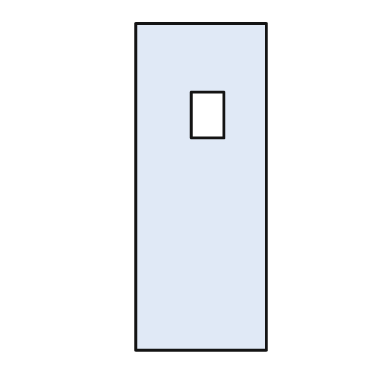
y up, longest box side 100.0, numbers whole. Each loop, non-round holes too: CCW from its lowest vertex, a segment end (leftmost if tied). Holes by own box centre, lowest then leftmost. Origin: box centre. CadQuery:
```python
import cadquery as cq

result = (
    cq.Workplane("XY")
    .moveTo(-20.0, -50.0)
    .lineTo(20.0, -50.0)
    .lineTo(20.0, 50.0)
    .lineTo(-20.0, 50.0)
    .close()
    .moveTo(-3.0, 15.0)
    .lineTo(7.0, 15.0)
    .lineTo(7.0, 29.0)
    .lineTo(-3.0, 29.0)
    .close()
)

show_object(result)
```